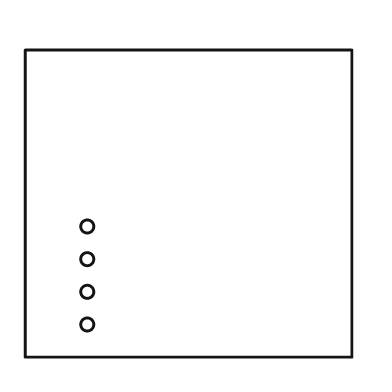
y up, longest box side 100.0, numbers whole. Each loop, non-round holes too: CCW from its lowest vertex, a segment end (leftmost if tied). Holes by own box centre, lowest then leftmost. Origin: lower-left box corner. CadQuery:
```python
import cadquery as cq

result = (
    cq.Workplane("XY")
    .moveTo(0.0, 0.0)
    .lineTo(100.0, 0.0)
    .lineTo(100.0, 94.0)
    .lineTo(0.0, 94.0)
    .close()
    .moveTo(19.0, 10.0)
    .circle(2.0)
    .moveTo(19.0, 20.0)
    .circle(2.0)
    .moveTo(19.0, 30.0)
    .circle(2.0)
    .moveTo(19.0, 40.0)
    .circle(2.0)
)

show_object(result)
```